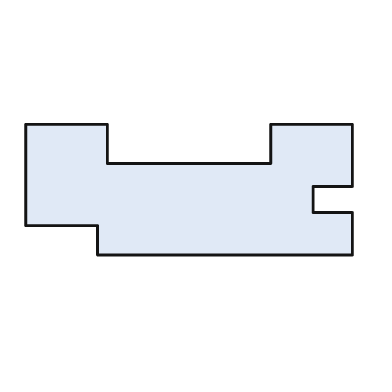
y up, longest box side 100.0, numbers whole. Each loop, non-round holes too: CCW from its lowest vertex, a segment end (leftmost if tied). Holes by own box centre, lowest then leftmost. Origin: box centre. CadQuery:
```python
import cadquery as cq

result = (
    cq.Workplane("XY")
    .moveTo(-28.0, -20.0)
    .lineTo(50.0, -20.0)
    .lineTo(50.0, -7.0)
    .lineTo(38.0, -7.0)
    .lineTo(38.0, 1.0)
    .lineTo(50.0, 1.0)
    .lineTo(50.0, 20.0)
    .lineTo(25.0, 20.0)
    .lineTo(25.0, 8.0)
    .lineTo(-25.0, 8.0)
    .lineTo(-25.0, 20.0)
    .lineTo(-50.0, 20.0)
    .lineTo(-50.0, -11.0)
    .lineTo(-28.0, -11.0)
    .close()
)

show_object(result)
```